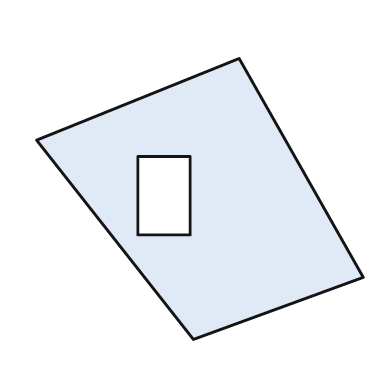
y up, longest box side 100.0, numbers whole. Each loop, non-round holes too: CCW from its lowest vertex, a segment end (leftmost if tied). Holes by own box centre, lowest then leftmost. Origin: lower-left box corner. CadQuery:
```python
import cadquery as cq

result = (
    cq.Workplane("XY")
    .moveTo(48.0, 0.0)
    .lineTo(100.0, 19.0)
    .lineTo(62.0, 86.0)
    .lineTo(0.0, 61.0)
    .close()
    .moveTo(31.0, 32.0)
    .lineTo(47.0, 32.0)
    .lineTo(47.0, 56.0)
    .lineTo(31.0, 56.0)
    .close()
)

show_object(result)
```